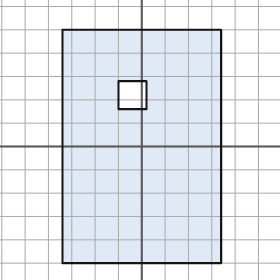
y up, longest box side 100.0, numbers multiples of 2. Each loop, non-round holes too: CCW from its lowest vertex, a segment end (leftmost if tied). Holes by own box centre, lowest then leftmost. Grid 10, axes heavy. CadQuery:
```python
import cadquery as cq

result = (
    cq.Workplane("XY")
    .moveTo(-34.0, -50.0)
    .lineTo(34.0, -50.0)
    .lineTo(34.0, 50.0)
    .lineTo(-34.0, 50.0)
    .close()
    .moveTo(-10.0, 16.0)
    .lineTo(2.0, 16.0)
    .lineTo(2.0, 28.0)
    .lineTo(-10.0, 28.0)
    .close()
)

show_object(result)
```